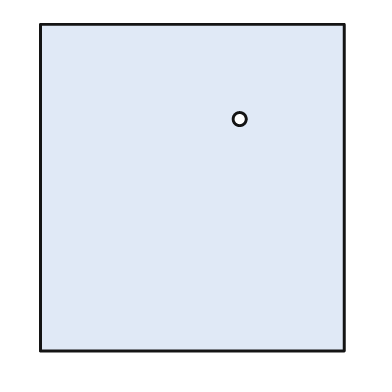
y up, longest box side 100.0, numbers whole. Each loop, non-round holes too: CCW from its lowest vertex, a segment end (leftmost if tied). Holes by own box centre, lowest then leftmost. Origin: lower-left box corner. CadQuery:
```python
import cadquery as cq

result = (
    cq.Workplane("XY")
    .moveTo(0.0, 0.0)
    .lineTo(93.0, 0.0)
    .lineTo(93.0, 100.0)
    .lineTo(0.0, 100.0)
    .close()
    .moveTo(61.0, 71.0)
    .circle(2.0)
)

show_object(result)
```